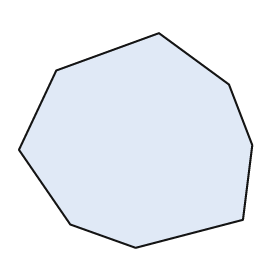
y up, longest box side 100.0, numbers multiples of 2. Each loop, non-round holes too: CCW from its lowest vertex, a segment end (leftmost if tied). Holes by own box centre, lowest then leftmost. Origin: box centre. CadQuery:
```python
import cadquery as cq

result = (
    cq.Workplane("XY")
    .moveTo(0.0, -46.0)
    .lineTo(46.0, -34.0)
    .lineTo(50.0, -2.0)
    .lineTo(40.0, 24.0)
    .lineTo(10.0, 46.0)
    .lineTo(-34.0, 30.0)
    .lineTo(-50.0, -4.0)
    .lineTo(-28.0, -36.0)
    .close()
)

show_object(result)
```